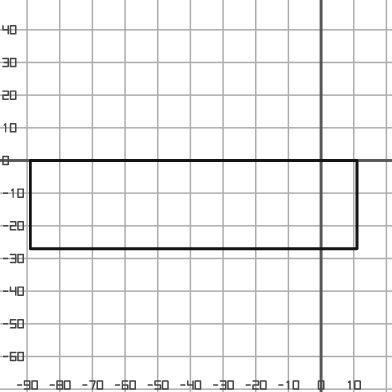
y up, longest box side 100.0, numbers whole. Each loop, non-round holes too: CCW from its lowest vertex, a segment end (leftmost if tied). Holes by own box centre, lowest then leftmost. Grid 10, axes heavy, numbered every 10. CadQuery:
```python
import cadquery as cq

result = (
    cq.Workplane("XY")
    .moveTo(-89.0, -27.0)
    .lineTo(11.0, -27.0)
    .lineTo(11.0, 0.0)
    .lineTo(-89.0, 0.0)
    .close()
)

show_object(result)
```